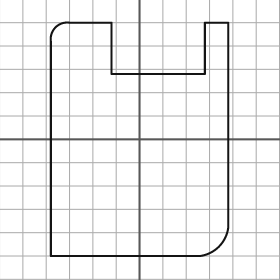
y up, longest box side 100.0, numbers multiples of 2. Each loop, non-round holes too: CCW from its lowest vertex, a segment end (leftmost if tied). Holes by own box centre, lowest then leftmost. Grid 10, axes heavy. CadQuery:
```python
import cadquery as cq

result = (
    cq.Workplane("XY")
    .moveTo(-38.0, -50.0)
    .lineTo(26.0, -50.0)
    .threePointArc((34.0, -46.0), (38.0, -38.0))
    .lineTo(38.0, 50.0)
    .lineTo(28.0, 50.0)
    .lineTo(28.0, 28.0)
    .lineTo(-12.0, 28.0)
    .lineTo(-12.0, 50.0)
    .lineTo(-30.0, 50.0)
    .threePointArc((-36.0, 48.0), (-38.0, 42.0))
    .close()
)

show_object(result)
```